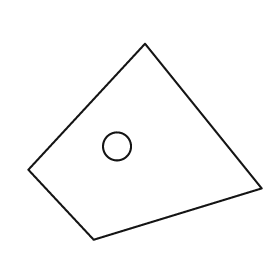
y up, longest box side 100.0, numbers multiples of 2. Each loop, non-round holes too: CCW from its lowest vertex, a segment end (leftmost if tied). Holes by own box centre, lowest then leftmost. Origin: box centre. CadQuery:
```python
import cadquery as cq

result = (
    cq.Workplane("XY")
    .moveTo(-22.0, -42.0)
    .lineTo(50.0, -20.0)
    .lineTo(0.0, 42.0)
    .lineTo(-50.0, -12.0)
    .close()
    .moveTo(-12.0, -2.0)
    .circle(6.0)
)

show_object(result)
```